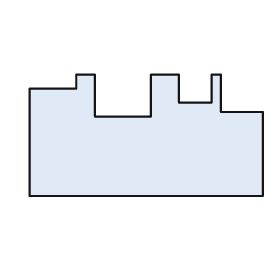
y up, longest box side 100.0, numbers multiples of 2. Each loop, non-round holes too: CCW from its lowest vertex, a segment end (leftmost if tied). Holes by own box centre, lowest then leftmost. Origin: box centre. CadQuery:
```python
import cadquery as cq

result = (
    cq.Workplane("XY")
    .moveTo(-50.0, -26.0)
    .lineTo(50.0, -26.0)
    .lineTo(50.0, 10.0)
    .lineTo(32.0, 10.0)
    .lineTo(32.0, 26.0)
    .lineTo(28.0, 26.0)
    .lineTo(28.0, 14.0)
    .lineTo(14.0, 14.0)
    .lineTo(14.0, 26.0)
    .lineTo(2.0, 26.0)
    .lineTo(2.0, 8.0)
    .lineTo(-22.0, 8.0)
    .lineTo(-22.0, 26.0)
    .lineTo(-30.0, 26.0)
    .lineTo(-30.0, 20.0)
    .lineTo(-50.0, 20.0)
    .close()
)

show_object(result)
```